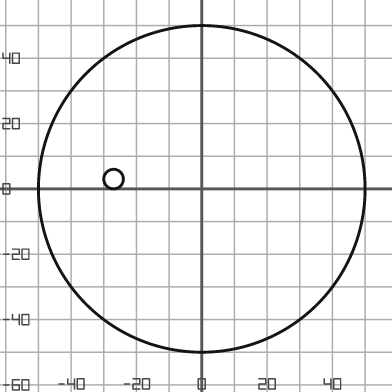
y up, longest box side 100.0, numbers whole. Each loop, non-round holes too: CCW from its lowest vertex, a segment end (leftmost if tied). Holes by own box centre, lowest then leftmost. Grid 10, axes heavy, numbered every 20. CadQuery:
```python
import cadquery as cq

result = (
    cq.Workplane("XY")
    .moveTo(0.0, 0.0)
    .circle(50.0)
    .moveTo(-27.0, 3.0)
    .circle(3.0)
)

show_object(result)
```